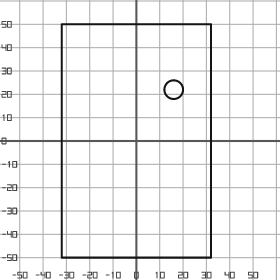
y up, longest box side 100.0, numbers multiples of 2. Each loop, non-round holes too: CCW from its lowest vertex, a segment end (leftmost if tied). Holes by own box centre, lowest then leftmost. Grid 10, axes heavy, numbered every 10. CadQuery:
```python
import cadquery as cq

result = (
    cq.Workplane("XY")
    .moveTo(-32.0, -50.0)
    .lineTo(32.0, -50.0)
    .lineTo(32.0, 50.0)
    .lineTo(-32.0, 50.0)
    .close()
    .moveTo(16.0, 22.0)
    .circle(4.0)
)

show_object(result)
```